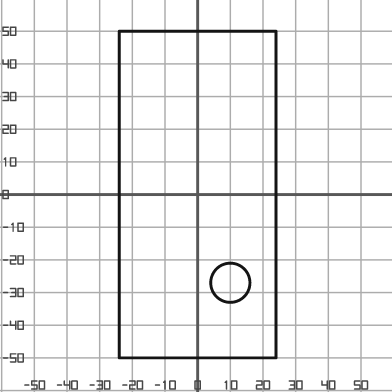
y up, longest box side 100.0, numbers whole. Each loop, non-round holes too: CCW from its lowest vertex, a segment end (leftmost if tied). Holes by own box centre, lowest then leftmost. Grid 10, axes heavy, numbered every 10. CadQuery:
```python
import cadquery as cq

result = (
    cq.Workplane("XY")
    .moveTo(-24.0, -50.0)
    .lineTo(24.0, -50.0)
    .lineTo(24.0, 50.0)
    .lineTo(-24.0, 50.0)
    .close()
    .moveTo(10.0, -27.0)
    .circle(6.0)
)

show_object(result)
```